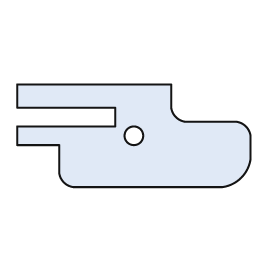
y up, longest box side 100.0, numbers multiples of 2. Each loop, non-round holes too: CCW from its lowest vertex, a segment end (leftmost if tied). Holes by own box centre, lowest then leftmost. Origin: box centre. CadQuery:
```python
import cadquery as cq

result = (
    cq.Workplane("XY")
    .moveTo(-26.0, -22.0)
    .lineTo(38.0, -22.0)
    .threePointArc((46.0, -18.0), (50.0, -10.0))
    .lineTo(50.0, 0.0)
    .threePointArc((48.0, 4.0), (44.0, 6.0))
    .lineTo(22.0, 6.0)
    .threePointArc((18.0, 8.0), (16.0, 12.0))
    .lineTo(16.0, 22.0)
    .lineTo(-50.0, 22.0)
    .lineTo(-50.0, 12.0)
    .lineTo(-8.0, 12.0)
    .lineTo(-8.0, 4.0)
    .lineTo(-50.0, 4.0)
    .lineTo(-50.0, -4.0)
    .lineTo(-32.0, -4.0)
    .lineTo(-32.0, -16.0)
    .threePointArc((-30.0, -20.0), (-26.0, -22.0))
    .close()
    .moveTo(0.0, 0.0)
    .circle(4.0)
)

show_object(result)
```